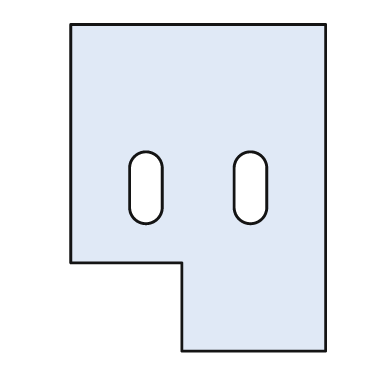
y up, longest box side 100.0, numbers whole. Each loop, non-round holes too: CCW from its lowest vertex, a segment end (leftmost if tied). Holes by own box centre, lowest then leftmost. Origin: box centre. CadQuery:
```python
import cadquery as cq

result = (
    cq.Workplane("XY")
    .moveTo(-5.0, -50.0)
    .lineTo(39.0, -50.0)
    .lineTo(39.0, 50.0)
    .lineTo(-39.0, 50.0)
    .lineTo(-39.0, -23.0)
    .lineTo(-5.0, -23.0)
    .close()
    .moveTo(-21.0, -6.0)
    .threePointArc((-16.0, -11.0), (-11.0, -6.0))
    .lineTo(-11.0, 6.0)
    .threePointArc((-16.0, 11.0), (-21.0, 6.0))
    .close()
    .moveTo(11.0, -6.0)
    .threePointArc((16.0, -11.0), (21.0, -6.0))
    .lineTo(21.0, 6.0)
    .threePointArc((16.0, 11.0), (11.0, 6.0))
    .close()
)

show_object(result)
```